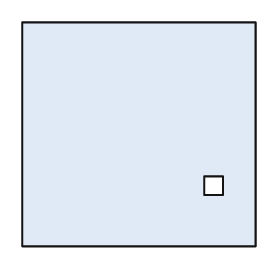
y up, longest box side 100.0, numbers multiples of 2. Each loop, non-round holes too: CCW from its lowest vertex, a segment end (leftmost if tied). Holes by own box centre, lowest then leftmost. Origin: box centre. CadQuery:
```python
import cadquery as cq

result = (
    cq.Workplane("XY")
    .moveTo(-50.0, -48.0)
    .lineTo(50.0, -48.0)
    .lineTo(50.0, 48.0)
    .lineTo(-50.0, 48.0)
    .close()
    .moveTo(28.0, -26.0)
    .lineTo(36.0, -26.0)
    .lineTo(36.0, -18.0)
    .lineTo(28.0, -18.0)
    .close()
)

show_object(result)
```